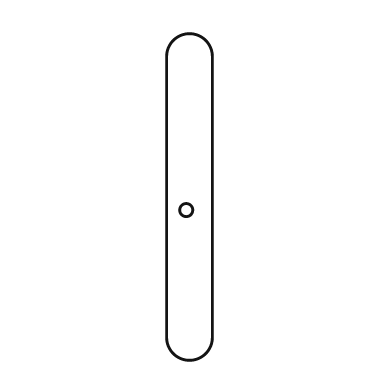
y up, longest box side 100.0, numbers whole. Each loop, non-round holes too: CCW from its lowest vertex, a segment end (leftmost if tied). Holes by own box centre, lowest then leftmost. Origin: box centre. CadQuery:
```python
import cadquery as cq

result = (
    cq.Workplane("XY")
    .moveTo(-7.0, -43.0)
    .threePointArc((0.0, -50.0), (7.0, -43.0))
    .lineTo(7.0, 43.0)
    .threePointArc((0.0, 50.0), (-7.0, 43.0))
    .close()
    .moveTo(-1.0, -4.0)
    .circle(2.0)
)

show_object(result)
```